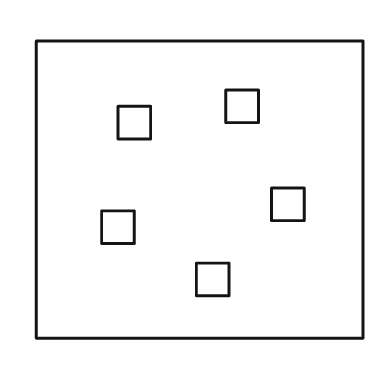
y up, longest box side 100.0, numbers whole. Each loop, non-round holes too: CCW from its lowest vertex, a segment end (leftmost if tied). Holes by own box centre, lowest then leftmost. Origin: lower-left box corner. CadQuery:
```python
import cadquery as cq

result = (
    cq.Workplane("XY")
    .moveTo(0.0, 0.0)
    .lineTo(100.0, 0.0)
    .lineTo(100.0, 91.0)
    .lineTo(0.0, 91.0)
    .close()
    .moveTo(49.0, 13.0)
    .lineTo(59.0, 13.0)
    .lineTo(59.0, 23.0)
    .lineTo(49.0, 23.0)
    .close()
    .moveTo(20.0, 29.0)
    .lineTo(30.0, 29.0)
    .lineTo(30.0, 39.0)
    .lineTo(20.0, 39.0)
    .close()
    .moveTo(72.0, 36.0)
    .lineTo(82.0, 36.0)
    .lineTo(82.0, 46.0)
    .lineTo(72.0, 46.0)
    .close()
    .moveTo(25.0, 61.0)
    .lineTo(35.0, 61.0)
    .lineTo(35.0, 71.0)
    .lineTo(25.0, 71.0)
    .close()
    .moveTo(58.0, 66.0)
    .lineTo(68.0, 66.0)
    .lineTo(68.0, 76.0)
    .lineTo(58.0, 76.0)
    .close()
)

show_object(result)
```